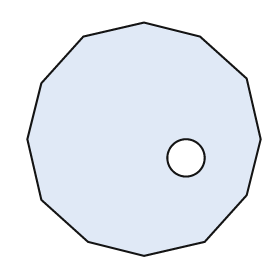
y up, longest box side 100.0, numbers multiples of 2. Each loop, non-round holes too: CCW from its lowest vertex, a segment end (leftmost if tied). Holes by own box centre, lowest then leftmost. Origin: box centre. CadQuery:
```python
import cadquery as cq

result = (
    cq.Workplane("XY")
    .moveTo(0.0, -50.0)
    .lineTo(26.0, -44.0)
    .lineTo(44.0, -24.0)
    .lineTo(50.0, 0.0)
    .lineTo(44.0, 26.0)
    .lineTo(24.0, 44.0)
    .lineTo(0.0, 50.0)
    .lineTo(-26.0, 44.0)
    .lineTo(-44.0, 24.0)
    .lineTo(-50.0, 0.0)
    .lineTo(-44.0, -26.0)
    .lineTo(-24.0, -44.0)
    .close()
    .moveTo(18.0, -8.0)
    .circle(8.0)
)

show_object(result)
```